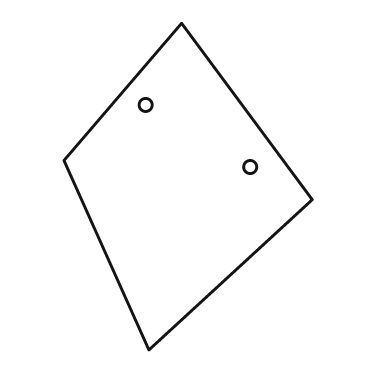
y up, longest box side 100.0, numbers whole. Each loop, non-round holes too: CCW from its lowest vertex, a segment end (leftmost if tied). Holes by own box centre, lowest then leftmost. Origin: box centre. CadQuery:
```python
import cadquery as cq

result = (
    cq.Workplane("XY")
    .moveTo(-12.0, -50.0)
    .lineTo(38.0, -4.0)
    .lineTo(-2.0, 50.0)
    .lineTo(-38.0, 8.0)
    .close()
    .moveTo(19.0, 6.0)
    .circle(2.0)
    .moveTo(-13.0, 25.0)
    .circle(2.0)
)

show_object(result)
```